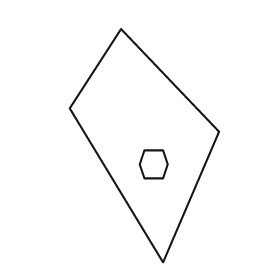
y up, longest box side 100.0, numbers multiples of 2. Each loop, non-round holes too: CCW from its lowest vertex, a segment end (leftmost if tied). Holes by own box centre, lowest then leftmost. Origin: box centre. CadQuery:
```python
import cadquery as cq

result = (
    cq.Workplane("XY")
    .moveTo(8.0, -50.0)
    .lineTo(32.0, 6.0)
    .lineTo(-10.0, 50.0)
    .lineTo(-32.0, 16.0)
    .close()
    .moveTo(0.0, -14.0)
    .lineTo(8.0, -14.0)
    .lineTo(10.0, -8.0)
    .lineTo(8.0, -2.0)
    .lineTo(0.0, -2.0)
    .lineTo(-2.0, -8.0)
    .close()
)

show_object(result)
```